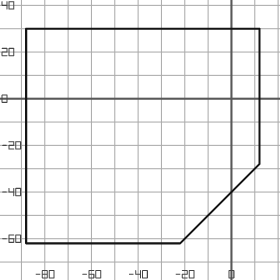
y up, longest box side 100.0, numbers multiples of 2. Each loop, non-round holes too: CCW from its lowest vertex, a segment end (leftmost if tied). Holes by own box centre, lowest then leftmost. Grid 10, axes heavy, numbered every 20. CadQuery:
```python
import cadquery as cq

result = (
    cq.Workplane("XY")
    .moveTo(-88.0, -62.0)
    .lineTo(-22.0, -62.0)
    .lineTo(12.0, -28.0)
    .lineTo(12.0, 30.0)
    .lineTo(-88.0, 30.0)
    .close()
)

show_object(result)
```